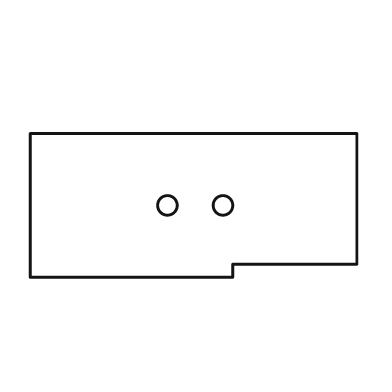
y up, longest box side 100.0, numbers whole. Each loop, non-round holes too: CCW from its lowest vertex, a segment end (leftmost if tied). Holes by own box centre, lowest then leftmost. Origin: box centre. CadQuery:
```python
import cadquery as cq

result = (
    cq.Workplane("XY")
    .moveTo(-50.0, -22.0)
    .lineTo(12.0, -22.0)
    .lineTo(12.0, -18.0)
    .lineTo(50.0, -18.0)
    .lineTo(50.0, 22.0)
    .lineTo(-50.0, 22.0)
    .close()
    .moveTo(-8.0, 0.0)
    .circle(3.0)
    .moveTo(9.0, 0.0)
    .circle(3.0)
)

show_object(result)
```